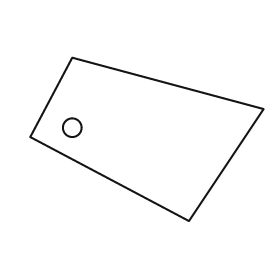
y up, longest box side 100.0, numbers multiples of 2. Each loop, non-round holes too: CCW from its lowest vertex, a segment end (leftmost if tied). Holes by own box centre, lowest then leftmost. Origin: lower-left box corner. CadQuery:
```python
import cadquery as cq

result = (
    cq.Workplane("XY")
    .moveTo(68.0, 0.0)
    .lineTo(100.0, 48.0)
    .lineTo(18.0, 70.0)
    .lineTo(0.0, 36.0)
    .close()
    .moveTo(18.0, 40.0)
    .circle(4.0)
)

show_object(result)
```